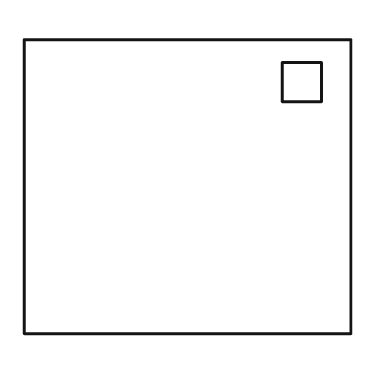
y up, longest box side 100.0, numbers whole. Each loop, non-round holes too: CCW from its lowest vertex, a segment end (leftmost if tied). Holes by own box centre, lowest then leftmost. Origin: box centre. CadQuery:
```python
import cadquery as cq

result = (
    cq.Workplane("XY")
    .moveTo(-50.0, -45.0)
    .lineTo(50.0, -45.0)
    .lineTo(50.0, 45.0)
    .lineTo(-50.0, 45.0)
    .close()
    .moveTo(29.0, 26.0)
    .lineTo(41.0, 26.0)
    .lineTo(41.0, 38.0)
    .lineTo(29.0, 38.0)
    .close()
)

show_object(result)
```